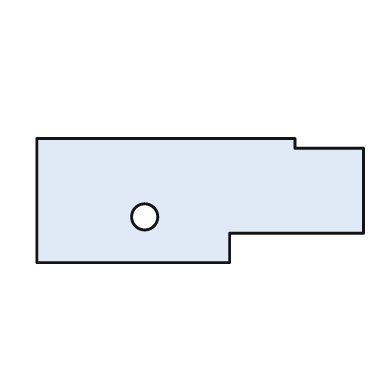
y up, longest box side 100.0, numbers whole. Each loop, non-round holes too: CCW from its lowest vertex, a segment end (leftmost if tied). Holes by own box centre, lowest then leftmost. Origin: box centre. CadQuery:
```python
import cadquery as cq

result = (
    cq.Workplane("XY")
    .moveTo(-50.0, -19.0)
    .lineTo(9.0, -19.0)
    .lineTo(9.0, -10.0)
    .lineTo(50.0, -10.0)
    .lineTo(50.0, 16.0)
    .lineTo(29.0, 16.0)
    .lineTo(29.0, 19.0)
    .lineTo(-50.0, 19.0)
    .close()
    .moveTo(-17.0, -5.0)
    .circle(4.0)
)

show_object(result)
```